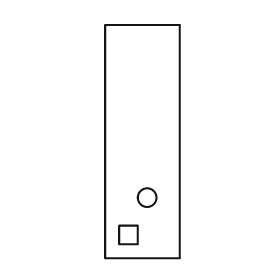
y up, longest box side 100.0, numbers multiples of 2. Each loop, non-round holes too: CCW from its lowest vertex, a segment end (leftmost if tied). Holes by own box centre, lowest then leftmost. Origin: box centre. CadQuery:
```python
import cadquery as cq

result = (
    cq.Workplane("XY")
    .moveTo(-16.0, -50.0)
    .lineTo(16.0, -50.0)
    .lineTo(16.0, 50.0)
    .lineTo(-16.0, 50.0)
    .close()
    .moveTo(-10.0, -44.0)
    .lineTo(-2.0, -44.0)
    .lineTo(-2.0, -36.0)
    .lineTo(-10.0, -36.0)
    .close()
    .moveTo(2.0, -24.0)
    .circle(4.0)
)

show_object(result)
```